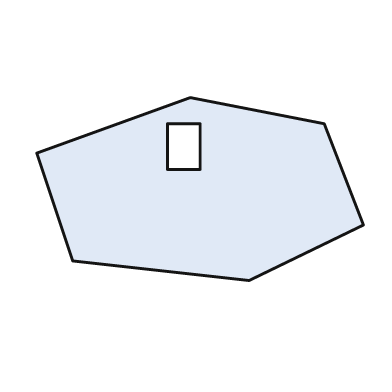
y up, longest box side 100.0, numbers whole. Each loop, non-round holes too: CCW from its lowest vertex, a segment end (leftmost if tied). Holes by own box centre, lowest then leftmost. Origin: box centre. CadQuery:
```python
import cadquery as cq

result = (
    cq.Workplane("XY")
    .moveTo(15.0, -28.0)
    .lineTo(50.0, -11.0)
    .lineTo(38.0, 20.0)
    .lineTo(-3.0, 28.0)
    .lineTo(-50.0, 11.0)
    .lineTo(-39.0, -22.0)
    .close()
    .moveTo(-10.0, 6.0)
    .lineTo(0.0, 6.0)
    .lineTo(0.0, 20.0)
    .lineTo(-10.0, 20.0)
    .close()
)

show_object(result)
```